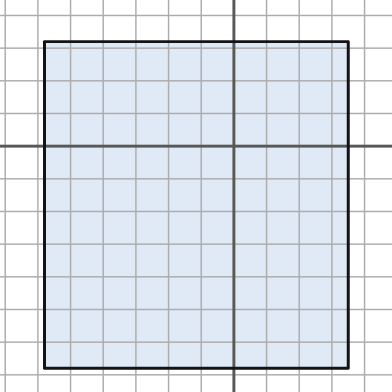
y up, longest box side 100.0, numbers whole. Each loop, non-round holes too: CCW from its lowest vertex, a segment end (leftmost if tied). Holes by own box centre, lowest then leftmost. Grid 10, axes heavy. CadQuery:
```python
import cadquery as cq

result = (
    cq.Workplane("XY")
    .moveTo(-58.0, -68.0)
    .lineTo(35.0, -68.0)
    .lineTo(35.0, 32.0)
    .lineTo(-58.0, 32.0)
    .close()
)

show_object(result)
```